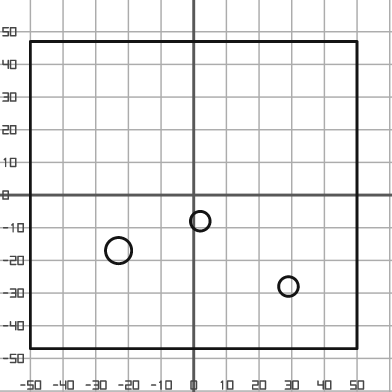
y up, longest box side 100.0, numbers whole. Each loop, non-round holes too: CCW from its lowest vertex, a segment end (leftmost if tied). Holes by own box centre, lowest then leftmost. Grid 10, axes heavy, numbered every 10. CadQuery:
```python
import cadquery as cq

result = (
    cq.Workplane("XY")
    .moveTo(-50.0, -47.0)
    .lineTo(50.0, -47.0)
    .lineTo(50.0, 47.0)
    .lineTo(-50.0, 47.0)
    .close()
    .moveTo(29.0, -28.0)
    .circle(3.0)
    .moveTo(-23.0, -17.0)
    .circle(4.0)
    .moveTo(2.0, -8.0)
    .circle(3.0)
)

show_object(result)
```